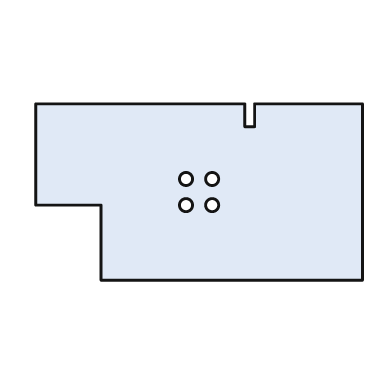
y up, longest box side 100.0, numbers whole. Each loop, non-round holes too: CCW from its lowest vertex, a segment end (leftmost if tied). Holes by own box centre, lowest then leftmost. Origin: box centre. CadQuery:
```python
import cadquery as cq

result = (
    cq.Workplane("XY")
    .moveTo(-30.0, -27.0)
    .lineTo(50.0, -27.0)
    .lineTo(50.0, 27.0)
    .lineTo(17.0, 27.0)
    .lineTo(17.0, 20.0)
    .lineTo(14.0, 20.0)
    .lineTo(14.0, 27.0)
    .lineTo(-50.0, 27.0)
    .lineTo(-50.0, -4.0)
    .lineTo(-30.0, -4.0)
    .close()
    .moveTo(-4.0, -4.0)
    .circle(2.0)
    .moveTo(4.0, -4.0)
    .circle(2.0)
    .moveTo(-4.0, 4.0)
    .circle(2.0)
    .moveTo(4.0, 4.0)
    .circle(2.0)
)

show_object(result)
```